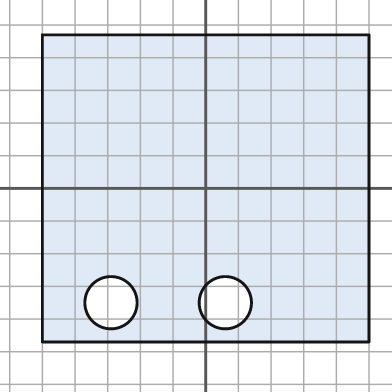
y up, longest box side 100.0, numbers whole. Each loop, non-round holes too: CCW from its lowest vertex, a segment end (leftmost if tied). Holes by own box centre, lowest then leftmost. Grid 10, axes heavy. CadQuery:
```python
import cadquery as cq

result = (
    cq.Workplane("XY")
    .moveTo(-50.0, -47.0)
    .lineTo(50.0, -47.0)
    .lineTo(50.0, 47.0)
    .lineTo(-50.0, 47.0)
    .close()
    .moveTo(-29.0, -35.0)
    .circle(8.0)
    .moveTo(6.0, -35.0)
    .circle(8.0)
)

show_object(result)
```